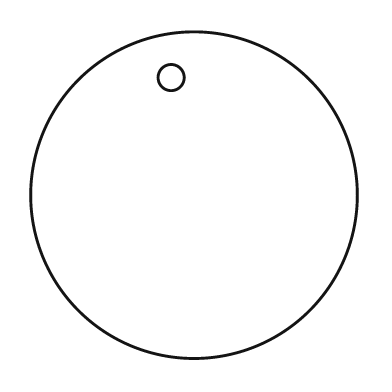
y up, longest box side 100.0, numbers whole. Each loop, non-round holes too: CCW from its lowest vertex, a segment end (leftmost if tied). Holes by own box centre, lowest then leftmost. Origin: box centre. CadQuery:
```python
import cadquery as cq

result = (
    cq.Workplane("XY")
    .moveTo(0.0, 0.0)
    .circle(50.0)
    .moveTo(-7.0, 36.0)
    .circle(4.0)
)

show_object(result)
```